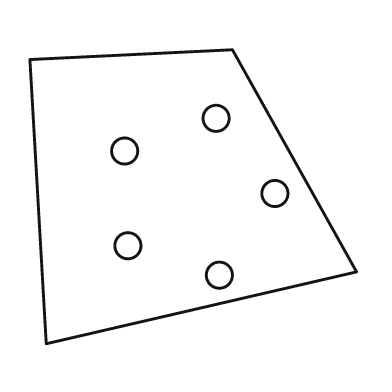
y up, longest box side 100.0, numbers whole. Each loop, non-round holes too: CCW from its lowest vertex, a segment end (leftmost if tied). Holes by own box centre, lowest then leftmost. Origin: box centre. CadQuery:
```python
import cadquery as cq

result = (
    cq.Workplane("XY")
    .moveTo(-45.0, -45.0)
    .lineTo(50.0, -23.0)
    .lineTo(12.0, 45.0)
    .lineTo(-50.0, 42.0)
    .close()
    .moveTo(8.0, -24.0)
    .circle(4.0)
    .moveTo(-20.0, -15.0)
    .circle(4.0)
    .moveTo(25.0, 1.0)
    .circle(4.0)
    .moveTo(-21.0, 14.0)
    .circle(4.0)
    .moveTo(7.0, 24.0)
    .circle(4.0)
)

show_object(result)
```